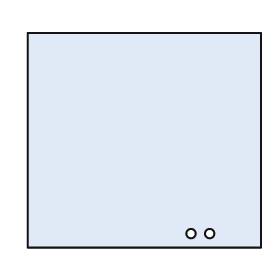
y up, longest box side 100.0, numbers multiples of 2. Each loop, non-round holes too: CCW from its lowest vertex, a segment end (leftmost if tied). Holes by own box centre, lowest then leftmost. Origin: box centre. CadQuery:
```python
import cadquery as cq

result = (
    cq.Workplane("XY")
    .moveTo(-50.0, -46.0)
    .lineTo(50.0, -46.0)
    .lineTo(50.0, 46.0)
    .lineTo(-50.0, 46.0)
    .close()
    .moveTo(20.0, -40.0)
    .circle(2.0)
    .moveTo(28.0, -40.0)
    .circle(2.0)
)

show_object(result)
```